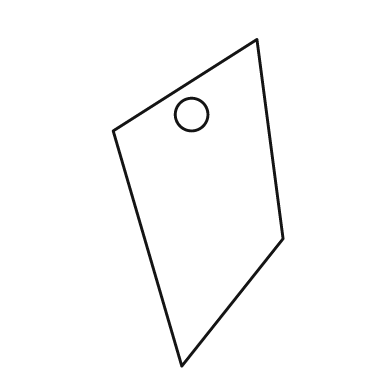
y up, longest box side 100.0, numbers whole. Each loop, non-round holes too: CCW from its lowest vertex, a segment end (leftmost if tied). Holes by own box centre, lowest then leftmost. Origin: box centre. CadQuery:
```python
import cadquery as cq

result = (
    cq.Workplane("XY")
    .moveTo(-5.0, -50.0)
    .lineTo(26.0, -11.0)
    .lineTo(18.0, 50.0)
    .lineTo(-26.0, 22.0)
    .close()
    .moveTo(-2.0, 27.0)
    .circle(5.0)
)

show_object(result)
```